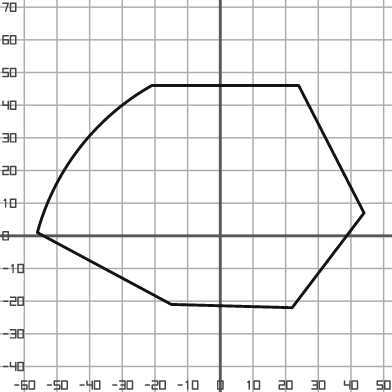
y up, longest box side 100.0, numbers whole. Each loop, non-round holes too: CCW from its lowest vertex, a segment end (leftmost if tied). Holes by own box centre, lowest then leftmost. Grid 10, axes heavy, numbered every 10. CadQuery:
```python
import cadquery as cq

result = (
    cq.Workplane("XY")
    .moveTo(22.0, -22.0)
    .lineTo(44.0, 7.0)
    .lineTo(24.0, 46.0)
    .lineTo(-21.0, 46.0)
    .threePointArc((-43.0, 27.0), (-56.0, 1.0))
    .lineTo(-15.0, -21.0)
    .close()
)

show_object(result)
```